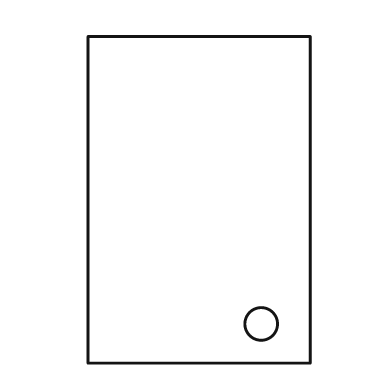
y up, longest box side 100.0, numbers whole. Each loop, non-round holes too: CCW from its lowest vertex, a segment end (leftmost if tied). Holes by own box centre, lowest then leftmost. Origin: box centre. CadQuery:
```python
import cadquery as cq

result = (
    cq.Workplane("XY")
    .moveTo(-34.0, -50.0)
    .lineTo(34.0, -50.0)
    .lineTo(34.0, 50.0)
    .lineTo(-34.0, 50.0)
    .close()
    .moveTo(19.0, -38.0)
    .circle(5.0)
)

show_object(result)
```